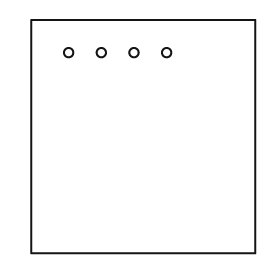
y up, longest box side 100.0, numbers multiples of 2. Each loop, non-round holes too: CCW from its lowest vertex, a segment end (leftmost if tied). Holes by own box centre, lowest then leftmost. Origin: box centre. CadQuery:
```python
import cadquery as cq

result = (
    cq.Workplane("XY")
    .moveTo(-48.0, -50.0)
    .lineTo(48.0, -50.0)
    .lineTo(48.0, 50.0)
    .lineTo(-48.0, 50.0)
    .close()
    .moveTo(-32.0, 36.0)
    .circle(2.0)
    .moveTo(-18.0, 36.0)
    .circle(2.0)
    .moveTo(-4.0, 36.0)
    .circle(2.0)
    .moveTo(10.0, 36.0)
    .circle(2.0)
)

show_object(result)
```